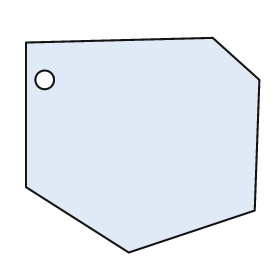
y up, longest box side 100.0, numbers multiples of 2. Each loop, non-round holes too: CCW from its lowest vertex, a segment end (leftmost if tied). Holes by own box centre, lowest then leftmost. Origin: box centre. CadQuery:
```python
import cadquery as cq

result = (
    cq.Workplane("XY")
    .moveTo(-6.0, -46.0)
    .lineTo(48.0, -28.0)
    .lineTo(50.0, 28.0)
    .lineTo(30.0, 46.0)
    .lineTo(-50.0, 44.0)
    .lineTo(-50.0, -18.0)
    .close()
    .moveTo(-42.0, 28.0)
    .circle(4.0)
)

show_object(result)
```